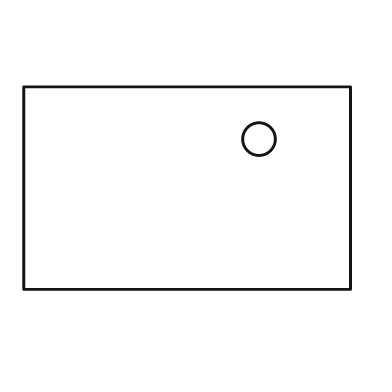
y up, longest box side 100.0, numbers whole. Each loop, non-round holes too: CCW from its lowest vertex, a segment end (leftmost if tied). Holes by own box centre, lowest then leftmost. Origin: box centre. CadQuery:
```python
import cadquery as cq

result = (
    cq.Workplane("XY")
    .moveTo(-50.0, -31.0)
    .lineTo(50.0, -31.0)
    .lineTo(50.0, 31.0)
    .lineTo(-50.0, 31.0)
    .close()
    .moveTo(22.0, 15.0)
    .circle(5.0)
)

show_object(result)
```